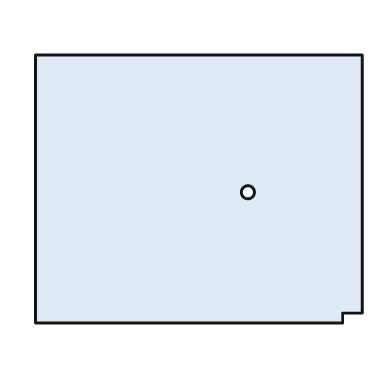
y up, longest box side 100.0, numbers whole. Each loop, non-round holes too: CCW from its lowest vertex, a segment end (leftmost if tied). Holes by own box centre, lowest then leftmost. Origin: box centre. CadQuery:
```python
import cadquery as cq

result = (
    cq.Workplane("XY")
    .moveTo(-50.0, -41.0)
    .lineTo(44.0, -41.0)
    .lineTo(44.0, -38.0)
    .lineTo(50.0, -38.0)
    .lineTo(50.0, 41.0)
    .lineTo(-50.0, 41.0)
    .close()
    .moveTo(15.0, -1.0)
    .circle(2.0)
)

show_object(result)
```